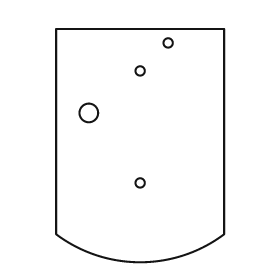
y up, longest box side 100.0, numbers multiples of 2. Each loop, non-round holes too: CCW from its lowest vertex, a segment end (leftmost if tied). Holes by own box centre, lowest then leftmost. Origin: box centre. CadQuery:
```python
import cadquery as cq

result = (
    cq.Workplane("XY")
    .moveTo(-36.0, -38.0)
    .threePointArc((0.0, -50.0), (36.0, -38.0))
    .lineTo(36.0, 50.0)
    .lineTo(-36.0, 50.0)
    .close()
    .moveTo(0.0, -16.0)
    .circle(2.0)
    .moveTo(-22.0, 14.0)
    .circle(4.0)
    .moveTo(0.0, 32.0)
    .circle(2.0)
    .moveTo(12.0, 44.0)
    .circle(2.0)
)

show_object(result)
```